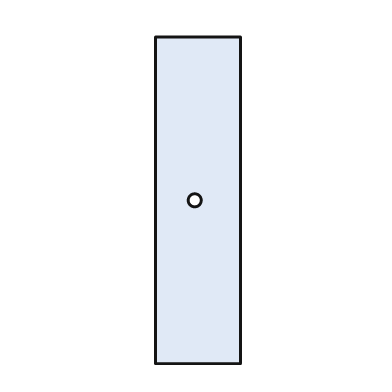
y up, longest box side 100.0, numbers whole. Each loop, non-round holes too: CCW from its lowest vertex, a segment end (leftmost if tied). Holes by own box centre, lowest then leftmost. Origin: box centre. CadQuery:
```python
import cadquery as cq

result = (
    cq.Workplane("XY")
    .moveTo(-13.0, -50.0)
    .lineTo(13.0, -50.0)
    .lineTo(13.0, 50.0)
    .lineTo(-13.0, 50.0)
    .close()
    .moveTo(-1.0, 0.0)
    .circle(2.0)
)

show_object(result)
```